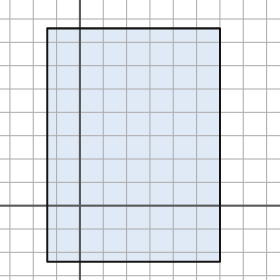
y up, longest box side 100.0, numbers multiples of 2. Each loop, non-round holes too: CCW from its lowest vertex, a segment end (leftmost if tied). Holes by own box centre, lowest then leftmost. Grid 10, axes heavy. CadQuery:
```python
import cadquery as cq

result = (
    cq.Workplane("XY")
    .moveTo(-14.0, -24.0)
    .lineTo(60.0, -24.0)
    .lineTo(60.0, 76.0)
    .lineTo(-14.0, 76.0)
    .close()
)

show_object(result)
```